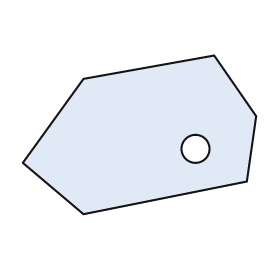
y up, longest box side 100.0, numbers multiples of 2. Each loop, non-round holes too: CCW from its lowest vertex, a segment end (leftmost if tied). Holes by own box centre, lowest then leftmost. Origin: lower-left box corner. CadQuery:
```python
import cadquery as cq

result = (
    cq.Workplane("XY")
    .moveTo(26.0, 0.0)
    .lineTo(96.0, 14.0)
    .lineTo(100.0, 42.0)
    .lineTo(82.0, 68.0)
    .lineTo(26.0, 58.0)
    .lineTo(0.0, 22.0)
    .close()
    .moveTo(74.0, 28.0)
    .circle(6.0)
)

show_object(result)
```